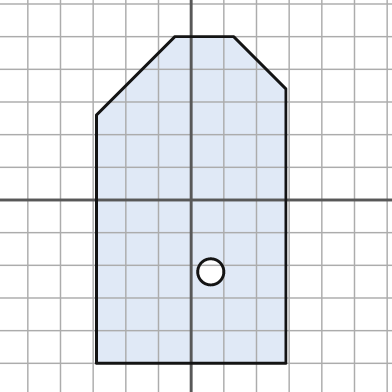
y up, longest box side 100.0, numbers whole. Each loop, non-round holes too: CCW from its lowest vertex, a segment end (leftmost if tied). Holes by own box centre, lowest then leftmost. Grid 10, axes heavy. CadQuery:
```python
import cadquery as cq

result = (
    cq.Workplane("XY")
    .moveTo(-29.0, -50.0)
    .lineTo(29.0, -50.0)
    .lineTo(29.0, 34.0)
    .lineTo(13.0, 50.0)
    .lineTo(-5.0, 50.0)
    .lineTo(-29.0, 26.0)
    .close()
    .moveTo(6.0, -22.0)
    .circle(4.0)
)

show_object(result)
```